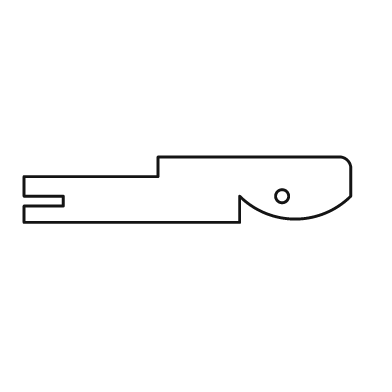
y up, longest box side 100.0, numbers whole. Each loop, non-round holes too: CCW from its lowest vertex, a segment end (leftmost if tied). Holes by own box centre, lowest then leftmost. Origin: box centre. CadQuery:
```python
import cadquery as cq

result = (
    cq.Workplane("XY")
    .moveTo(-50.0, -10.0)
    .lineTo(16.0, -10.0)
    .lineTo(16.0, -2.0)
    .threePointArc((33.0, -9.0), (50.0, -2.0))
    .lineTo(50.0, 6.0)
    .threePointArc((49.0, 9.0), (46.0, 10.0))
    .lineTo(-9.0, 10.0)
    .lineTo(-9.0, 4.0)
    .lineTo(-50.0, 4.0)
    .lineTo(-50.0, -2.0)
    .lineTo(-38.0, -2.0)
    .lineTo(-38.0, -5.0)
    .lineTo(-50.0, -5.0)
    .close()
    .moveTo(29.0, -2.0)
    .circle(2.0)
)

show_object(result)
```